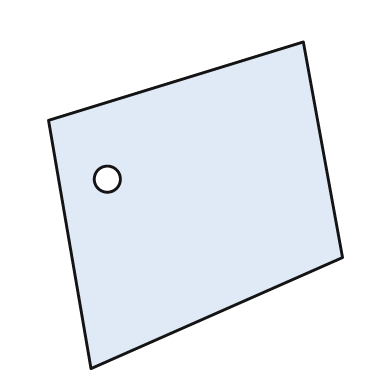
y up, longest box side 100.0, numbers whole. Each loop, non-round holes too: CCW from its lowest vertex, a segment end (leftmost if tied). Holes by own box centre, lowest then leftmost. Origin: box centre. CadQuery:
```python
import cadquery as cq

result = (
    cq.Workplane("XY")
    .moveTo(-32.0, -50.0)
    .lineTo(45.0, -16.0)
    .lineTo(33.0, 50.0)
    .lineTo(-45.0, 26.0)
    .close()
    .moveTo(-27.0, 8.0)
    .circle(4.0)
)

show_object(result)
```